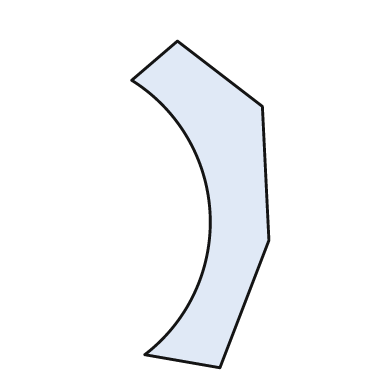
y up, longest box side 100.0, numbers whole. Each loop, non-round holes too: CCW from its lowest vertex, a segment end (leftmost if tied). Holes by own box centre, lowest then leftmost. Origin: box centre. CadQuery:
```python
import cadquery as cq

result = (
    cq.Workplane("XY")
    .moveTo(6.0, -50.0)
    .lineTo(21.0, -11.0)
    .lineTo(19.0, 30.0)
    .lineTo(-7.0, 50.0)
    .lineTo(-21.0, 38.0)
    .threePointArc((3.0, -3.0), (-17.0, -46.0))
    .close()
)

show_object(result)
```